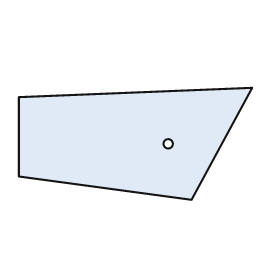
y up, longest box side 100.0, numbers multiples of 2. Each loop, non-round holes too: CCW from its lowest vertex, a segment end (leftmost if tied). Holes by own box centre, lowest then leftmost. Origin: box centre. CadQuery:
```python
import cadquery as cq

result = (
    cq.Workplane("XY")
    .moveTo(24.0, -24.0)
    .lineTo(50.0, 24.0)
    .lineTo(-50.0, 20.0)
    .lineTo(-50.0, -14.0)
    .close()
    .moveTo(14.0, 0.0)
    .circle(2.0)
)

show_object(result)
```